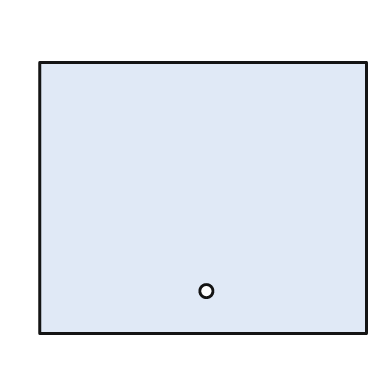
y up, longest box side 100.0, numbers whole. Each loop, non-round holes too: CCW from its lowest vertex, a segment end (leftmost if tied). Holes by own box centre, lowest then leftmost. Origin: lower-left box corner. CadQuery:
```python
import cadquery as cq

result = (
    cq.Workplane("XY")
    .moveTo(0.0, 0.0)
    .lineTo(100.0, 0.0)
    .lineTo(100.0, 83.0)
    .lineTo(0.0, 83.0)
    .close()
    .moveTo(51.0, 13.0)
    .circle(2.0)
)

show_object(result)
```